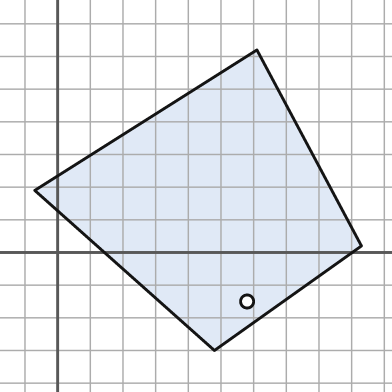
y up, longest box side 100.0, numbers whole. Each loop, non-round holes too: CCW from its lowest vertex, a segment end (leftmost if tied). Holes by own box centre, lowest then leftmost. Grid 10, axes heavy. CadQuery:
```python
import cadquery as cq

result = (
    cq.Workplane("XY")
    .moveTo(48.0, -30.0)
    .lineTo(93.0, 2.0)
    .lineTo(61.0, 62.0)
    .lineTo(-7.0, 19.0)
    .close()
    .moveTo(58.0, -15.0)
    .circle(2.0)
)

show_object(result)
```